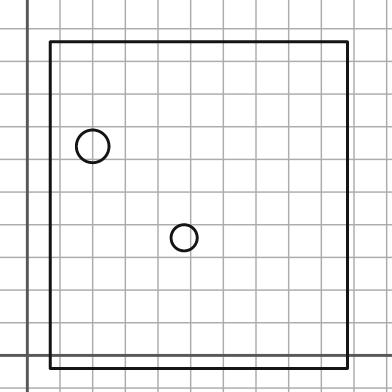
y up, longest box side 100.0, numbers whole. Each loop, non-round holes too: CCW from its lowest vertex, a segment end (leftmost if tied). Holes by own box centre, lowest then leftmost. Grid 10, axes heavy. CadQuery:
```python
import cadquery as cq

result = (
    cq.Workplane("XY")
    .moveTo(7.0, -4.0)
    .lineTo(98.0, -4.0)
    .lineTo(98.0, 96.0)
    .lineTo(7.0, 96.0)
    .close()
    .moveTo(48.0, 36.0)
    .circle(4.0)
    .moveTo(20.0, 64.0)
    .circle(5.0)
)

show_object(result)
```